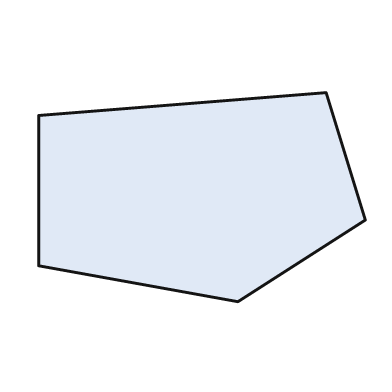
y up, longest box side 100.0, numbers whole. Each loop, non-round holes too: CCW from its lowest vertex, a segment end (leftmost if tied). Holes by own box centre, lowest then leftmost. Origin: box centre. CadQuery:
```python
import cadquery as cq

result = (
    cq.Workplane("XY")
    .moveTo(11.0, -32.0)
    .lineTo(50.0, -7.0)
    .lineTo(38.0, 32.0)
    .lineTo(-50.0, 25.0)
    .lineTo(-50.0, -21.0)
    .close()
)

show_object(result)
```